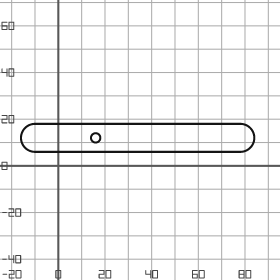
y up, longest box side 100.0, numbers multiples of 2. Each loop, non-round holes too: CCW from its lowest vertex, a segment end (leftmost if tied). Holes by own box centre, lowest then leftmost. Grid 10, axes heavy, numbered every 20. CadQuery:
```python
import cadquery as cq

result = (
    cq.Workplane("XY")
    .moveTo(-10.0, 6.0)
    .lineTo(78.0, 6.0)
    .threePointArc((84.0, 12.0), (78.0, 18.0))
    .lineTo(-10.0, 18.0)
    .threePointArc((-16.0, 12.0), (-10.0, 6.0))
    .close()
    .moveTo(16.0, 12.0)
    .circle(2.0)
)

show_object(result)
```